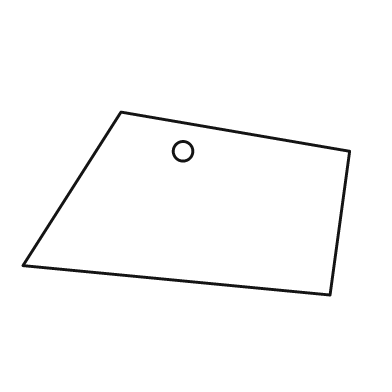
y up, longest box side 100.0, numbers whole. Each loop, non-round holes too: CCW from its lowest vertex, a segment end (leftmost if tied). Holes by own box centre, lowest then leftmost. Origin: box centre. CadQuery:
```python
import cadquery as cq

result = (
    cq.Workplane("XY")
    .moveTo(44.0, -28.0)
    .lineTo(50.0, 16.0)
    .lineTo(-20.0, 28.0)
    .lineTo(-50.0, -19.0)
    .close()
    .moveTo(-1.0, 16.0)
    .circle(3.0)
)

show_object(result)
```